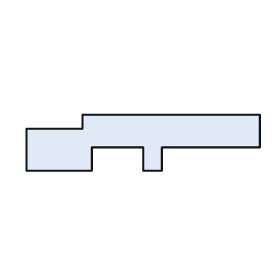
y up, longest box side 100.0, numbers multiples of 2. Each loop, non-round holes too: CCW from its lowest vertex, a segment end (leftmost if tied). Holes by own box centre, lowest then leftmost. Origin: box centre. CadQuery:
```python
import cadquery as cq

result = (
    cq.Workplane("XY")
    .moveTo(-50.0, -12.0)
    .lineTo(-22.0, -12.0)
    .lineTo(-22.0, -2.0)
    .lineTo(0.0, -2.0)
    .lineTo(0.0, -12.0)
    .lineTo(8.0, -12.0)
    .lineTo(8.0, -2.0)
    .lineTo(50.0, -2.0)
    .lineTo(50.0, 12.0)
    .lineTo(-26.0, 12.0)
    .lineTo(-26.0, 6.0)
    .lineTo(-50.0, 6.0)
    .close()
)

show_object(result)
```